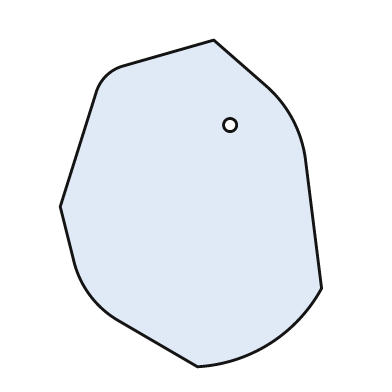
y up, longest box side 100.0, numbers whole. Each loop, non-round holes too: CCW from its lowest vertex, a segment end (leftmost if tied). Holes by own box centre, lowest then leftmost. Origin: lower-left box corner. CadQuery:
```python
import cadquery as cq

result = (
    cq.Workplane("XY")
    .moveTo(42.0, 0.0)
    .threePointArc((64.0, 7.0), (80.0, 24.0))
    .lineTo(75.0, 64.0)
    .threePointArc((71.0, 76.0), (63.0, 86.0))
    .lineTo(47.0, 100.0)
    .lineTo(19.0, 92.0)
    .threePointArc((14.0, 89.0), (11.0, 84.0))
    .lineTo(0.0, 49.0)
    .lineTo(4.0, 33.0)
    .threePointArc((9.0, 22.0), (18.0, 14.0))
    .close()
    .moveTo(52.0, 74.0)
    .circle(2.0)
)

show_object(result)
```